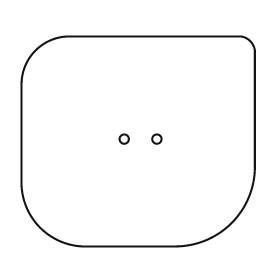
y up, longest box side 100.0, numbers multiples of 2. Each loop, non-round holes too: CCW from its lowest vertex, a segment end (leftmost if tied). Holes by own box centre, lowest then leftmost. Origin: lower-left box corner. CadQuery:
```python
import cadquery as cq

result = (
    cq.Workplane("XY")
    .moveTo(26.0, 0.0)
    .lineTo(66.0, 0.0)
    .threePointArc((90.0, 10.0), (100.0, 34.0))
    .lineTo(100.0, 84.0)
    .threePointArc((98.0, 88.0), (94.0, 90.0))
    .lineTo(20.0, 90.0)
    .threePointArc((6.0, 84.0), (0.0, 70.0))
    .lineTo(0.0, 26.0)
    .threePointArc((8.0, 8.0), (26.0, 0.0))
    .close()
    .moveTo(44.0, 46.0)
    .circle(2.0)
    .moveTo(58.0, 46.0)
    .circle(2.0)
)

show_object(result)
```